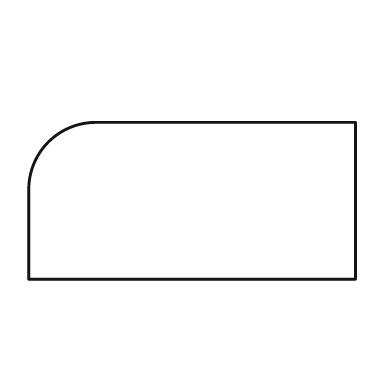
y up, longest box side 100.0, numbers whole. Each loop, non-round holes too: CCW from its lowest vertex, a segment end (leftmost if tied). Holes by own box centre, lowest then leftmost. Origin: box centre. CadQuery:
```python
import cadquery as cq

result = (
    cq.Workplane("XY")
    .moveTo(-50.0, -24.0)
    .lineTo(50.0, -24.0)
    .lineTo(50.0, 24.0)
    .lineTo(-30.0, 24.0)
    .threePointArc((-44.0, 18.0), (-50.0, 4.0))
    .close()
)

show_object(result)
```